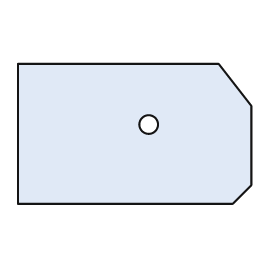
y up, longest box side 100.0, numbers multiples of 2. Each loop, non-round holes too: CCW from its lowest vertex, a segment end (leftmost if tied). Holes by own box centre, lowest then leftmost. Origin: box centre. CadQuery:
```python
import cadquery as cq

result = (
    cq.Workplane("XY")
    .moveTo(-50.0, -30.0)
    .lineTo(42.0, -30.0)
    .lineTo(50.0, -22.0)
    .lineTo(50.0, 12.0)
    .lineTo(36.0, 30.0)
    .lineTo(-50.0, 30.0)
    .close()
    .moveTo(6.0, 4.0)
    .circle(4.0)
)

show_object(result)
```